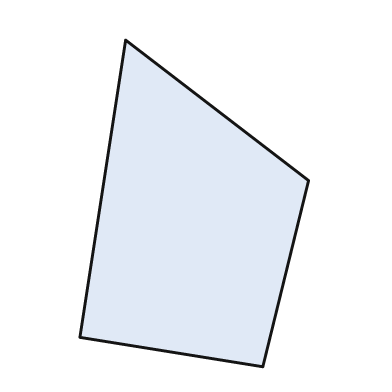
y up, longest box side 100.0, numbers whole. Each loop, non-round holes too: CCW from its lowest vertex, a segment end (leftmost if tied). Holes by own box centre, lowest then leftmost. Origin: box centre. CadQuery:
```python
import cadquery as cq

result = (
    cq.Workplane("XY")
    .moveTo(21.0, -50.0)
    .lineTo(35.0, 7.0)
    .lineTo(-21.0, 50.0)
    .lineTo(-35.0, -41.0)
    .close()
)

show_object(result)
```